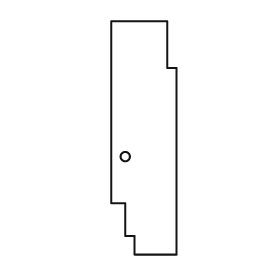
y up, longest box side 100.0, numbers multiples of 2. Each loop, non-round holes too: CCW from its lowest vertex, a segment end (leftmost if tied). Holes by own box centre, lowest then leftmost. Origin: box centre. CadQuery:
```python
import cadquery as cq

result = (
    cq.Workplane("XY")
    .moveTo(-4.0, -50.0)
    .lineTo(14.0, -50.0)
    .lineTo(14.0, 30.0)
    .lineTo(10.0, 30.0)
    .lineTo(10.0, 50.0)
    .lineTo(-14.0, 50.0)
    .lineTo(-14.0, -28.0)
    .lineTo(-8.0, -28.0)
    .lineTo(-8.0, -42.0)
    .lineTo(-4.0, -42.0)
    .close()
    .moveTo(-8.0, -8.0)
    .circle(2.0)
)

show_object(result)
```